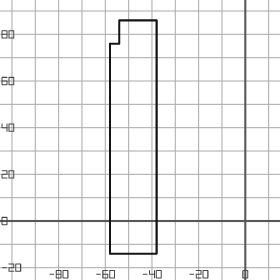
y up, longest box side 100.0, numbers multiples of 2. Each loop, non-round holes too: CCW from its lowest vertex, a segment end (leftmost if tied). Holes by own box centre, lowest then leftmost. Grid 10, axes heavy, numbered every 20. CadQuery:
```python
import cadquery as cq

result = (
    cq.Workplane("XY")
    .moveTo(-58.0, -14.0)
    .lineTo(-38.0, -14.0)
    .lineTo(-38.0, 86.0)
    .lineTo(-54.0, 86.0)
    .lineTo(-54.0, 76.0)
    .lineTo(-58.0, 76.0)
    .close()
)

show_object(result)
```